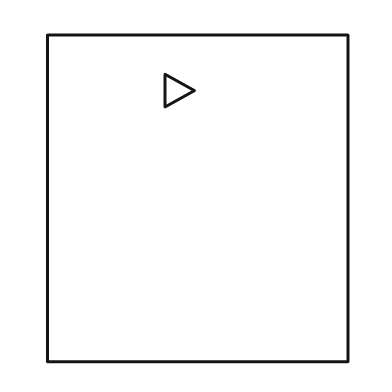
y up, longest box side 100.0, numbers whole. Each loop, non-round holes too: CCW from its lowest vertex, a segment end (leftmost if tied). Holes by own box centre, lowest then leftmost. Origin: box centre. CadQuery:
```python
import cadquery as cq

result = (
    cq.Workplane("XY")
    .moveTo(-46.0, -50.0)
    .lineTo(46.0, -50.0)
    .lineTo(46.0, 50.0)
    .lineTo(-46.0, 50.0)
    .close()
    .moveTo(-10.0, 28.0)
    .lineTo(-1.0, 33.0)
    .lineTo(-10.0, 38.0)
    .close()
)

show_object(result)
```